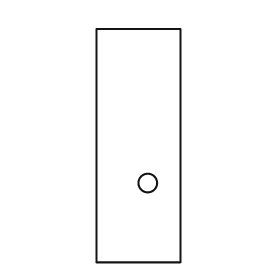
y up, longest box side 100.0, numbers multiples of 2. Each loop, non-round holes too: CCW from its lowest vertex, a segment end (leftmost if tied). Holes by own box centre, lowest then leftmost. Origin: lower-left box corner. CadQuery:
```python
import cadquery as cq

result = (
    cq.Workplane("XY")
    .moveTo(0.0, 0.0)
    .lineTo(36.0, 0.0)
    .lineTo(36.0, 100.0)
    .lineTo(0.0, 100.0)
    .close()
    .moveTo(22.0, 34.0)
    .circle(4.0)
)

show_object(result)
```